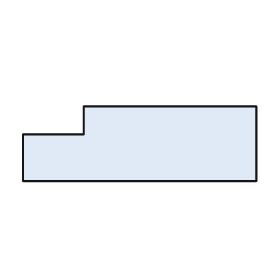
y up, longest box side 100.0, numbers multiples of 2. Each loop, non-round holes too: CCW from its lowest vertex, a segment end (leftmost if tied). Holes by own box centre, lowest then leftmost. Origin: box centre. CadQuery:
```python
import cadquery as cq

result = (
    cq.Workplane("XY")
    .moveTo(-50.0, -16.0)
    .lineTo(50.0, -16.0)
    .lineTo(50.0, 16.0)
    .lineTo(-24.0, 16.0)
    .lineTo(-24.0, 4.0)
    .lineTo(-50.0, 4.0)
    .close()
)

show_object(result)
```